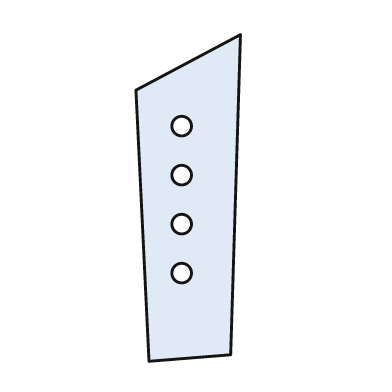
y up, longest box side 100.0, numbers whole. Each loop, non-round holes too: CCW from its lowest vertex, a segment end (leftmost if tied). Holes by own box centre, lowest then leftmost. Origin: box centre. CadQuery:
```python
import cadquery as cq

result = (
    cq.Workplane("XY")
    .moveTo(-12.0, -50.0)
    .lineTo(13.0, -48.0)
    .lineTo(16.0, 50.0)
    .lineTo(-16.0, 33.0)
    .close()
    .moveTo(-2.0, -23.0)
    .circle(3.0)
    .moveTo(-2.0, -8.0)
    .circle(3.0)
    .moveTo(-2.0, 7.0)
    .circle(3.0)
    .moveTo(-2.0, 22.0)
    .circle(3.0)
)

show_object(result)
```